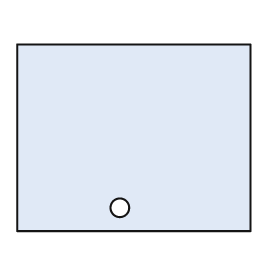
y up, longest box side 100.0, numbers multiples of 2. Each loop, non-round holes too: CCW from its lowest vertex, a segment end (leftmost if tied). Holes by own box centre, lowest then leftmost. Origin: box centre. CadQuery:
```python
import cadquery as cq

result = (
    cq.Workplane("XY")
    .moveTo(-50.0, -40.0)
    .lineTo(50.0, -40.0)
    .lineTo(50.0, 40.0)
    .lineTo(-50.0, 40.0)
    .close()
    .moveTo(-6.0, -30.0)
    .circle(4.0)
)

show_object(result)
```